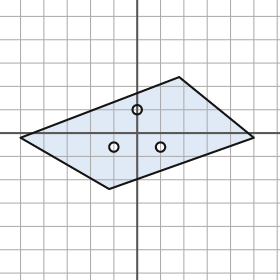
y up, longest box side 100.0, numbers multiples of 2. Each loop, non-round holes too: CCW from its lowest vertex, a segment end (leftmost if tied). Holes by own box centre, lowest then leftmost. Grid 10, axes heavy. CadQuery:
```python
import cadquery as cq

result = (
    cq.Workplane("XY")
    .moveTo(-12.0, -24.0)
    .lineTo(50.0, -2.0)
    .lineTo(18.0, 24.0)
    .lineTo(-50.0, -2.0)
    .close()
    .moveTo(-10.0, -6.0)
    .circle(2.0)
    .moveTo(10.0, -6.0)
    .circle(2.0)
    .moveTo(0.0, 10.0)
    .circle(2.0)
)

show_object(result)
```